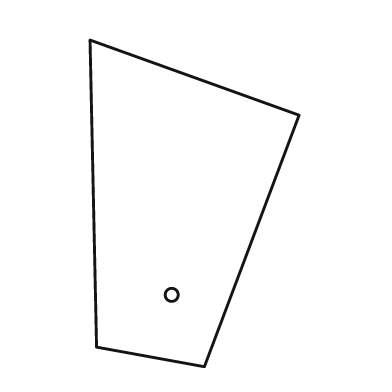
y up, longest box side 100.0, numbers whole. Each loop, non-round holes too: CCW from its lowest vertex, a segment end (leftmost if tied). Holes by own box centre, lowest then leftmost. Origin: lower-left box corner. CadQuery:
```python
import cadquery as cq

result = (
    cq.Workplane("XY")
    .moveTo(35.0, 0.0)
    .lineTo(64.0, 77.0)
    .lineTo(0.0, 100.0)
    .lineTo(2.0, 6.0)
    .close()
    .moveTo(25.0, 22.0)
    .circle(2.0)
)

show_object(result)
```